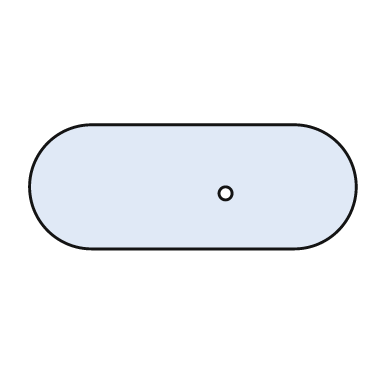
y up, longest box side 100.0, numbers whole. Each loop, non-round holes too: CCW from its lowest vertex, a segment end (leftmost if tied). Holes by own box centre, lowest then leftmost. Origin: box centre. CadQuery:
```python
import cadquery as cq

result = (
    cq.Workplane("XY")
    .moveTo(-31.0, -19.0)
    .lineTo(31.0, -19.0)
    .threePointArc((50.0, 0.0), (31.0, 19.0))
    .lineTo(-31.0, 19.0)
    .threePointArc((-50.0, 0.0), (-31.0, -19.0))
    .close()
    .moveTo(10.0, -2.0)
    .circle(2.0)
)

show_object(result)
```